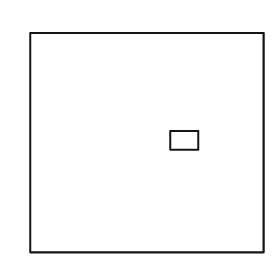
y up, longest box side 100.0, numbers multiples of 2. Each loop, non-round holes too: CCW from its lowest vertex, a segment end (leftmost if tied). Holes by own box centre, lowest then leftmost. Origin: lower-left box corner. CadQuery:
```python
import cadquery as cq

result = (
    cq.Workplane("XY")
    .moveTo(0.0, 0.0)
    .lineTo(100.0, 0.0)
    .lineTo(100.0, 94.0)
    .lineTo(0.0, 94.0)
    .close()
    .moveTo(60.0, 44.0)
    .lineTo(72.0, 44.0)
    .lineTo(72.0, 52.0)
    .lineTo(60.0, 52.0)
    .close()
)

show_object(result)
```